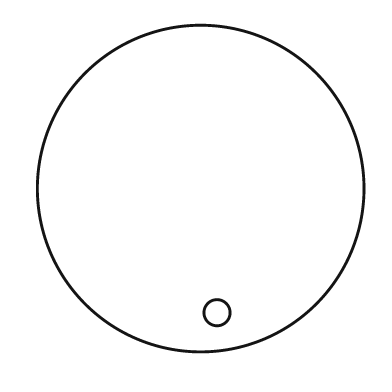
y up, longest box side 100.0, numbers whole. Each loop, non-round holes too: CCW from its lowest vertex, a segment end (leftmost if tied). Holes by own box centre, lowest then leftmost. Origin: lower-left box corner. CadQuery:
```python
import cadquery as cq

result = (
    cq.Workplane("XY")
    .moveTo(50.0, 50.0)
    .circle(50.0)
    .moveTo(55.0, 12.0)
    .circle(4.0)
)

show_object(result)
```